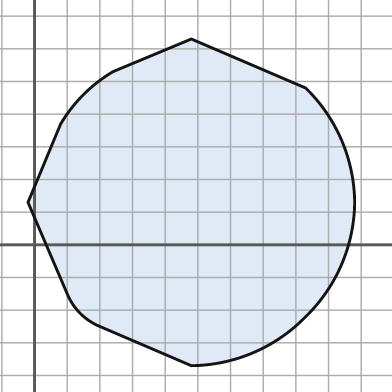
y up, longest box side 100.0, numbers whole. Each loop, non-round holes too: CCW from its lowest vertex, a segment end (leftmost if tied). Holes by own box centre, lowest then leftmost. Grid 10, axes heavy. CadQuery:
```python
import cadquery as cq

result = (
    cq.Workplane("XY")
    .moveTo(48.0, -37.0)
    .threePointArc((67.0, -33.0), (83.0, -22.0))
    .threePointArc((94.0, -6.0), (98.0, 13.0))
    .threePointArc((94.0, 32.0), (83.0, 48.0))
    .lineTo(48.0, 63.0)
    .lineTo(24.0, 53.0)
    .threePointArc((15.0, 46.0), (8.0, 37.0))
    .lineTo(-2.0, 13.0)
    .lineTo(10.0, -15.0)
    .threePointArc((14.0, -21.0), (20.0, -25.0))
    .close()
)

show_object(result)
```